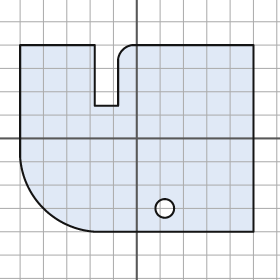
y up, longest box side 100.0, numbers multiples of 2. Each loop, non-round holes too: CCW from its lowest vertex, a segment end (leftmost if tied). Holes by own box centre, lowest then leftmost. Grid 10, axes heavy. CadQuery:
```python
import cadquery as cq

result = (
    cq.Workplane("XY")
    .moveTo(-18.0, -40.0)
    .lineTo(50.0, -40.0)
    .lineTo(50.0, 40.0)
    .lineTo(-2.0, 40.0)
    .threePointArc((-6.0, 38.0), (-8.0, 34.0))
    .lineTo(-8.0, 14.0)
    .lineTo(-18.0, 14.0)
    .lineTo(-18.0, 40.0)
    .lineTo(-50.0, 40.0)
    .lineTo(-50.0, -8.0)
    .threePointArc((-40.0, -30.0), (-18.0, -40.0))
    .close()
    .moveTo(12.0, -30.0)
    .circle(4.0)
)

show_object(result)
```